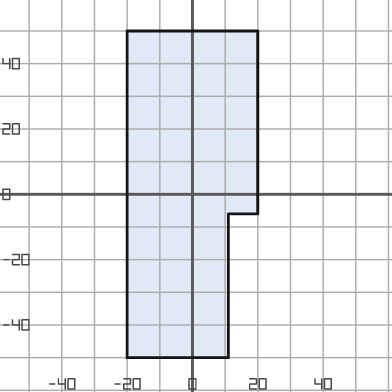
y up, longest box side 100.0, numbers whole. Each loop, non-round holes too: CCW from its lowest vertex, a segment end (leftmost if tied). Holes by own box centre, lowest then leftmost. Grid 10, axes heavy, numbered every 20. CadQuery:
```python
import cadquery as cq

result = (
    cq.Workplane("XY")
    .moveTo(-20.0, -50.0)
    .lineTo(11.0, -50.0)
    .lineTo(11.0, -6.0)
    .lineTo(20.0, -6.0)
    .lineTo(20.0, 50.0)
    .lineTo(-20.0, 50.0)
    .close()
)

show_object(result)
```